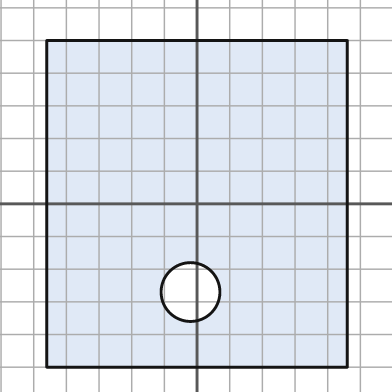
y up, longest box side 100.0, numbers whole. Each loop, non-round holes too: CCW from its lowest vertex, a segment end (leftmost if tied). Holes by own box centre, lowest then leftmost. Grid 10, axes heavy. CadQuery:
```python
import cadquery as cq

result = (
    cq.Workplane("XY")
    .moveTo(-46.0, -50.0)
    .lineTo(46.0, -50.0)
    .lineTo(46.0, 50.0)
    .lineTo(-46.0, 50.0)
    .close()
    .moveTo(-2.0, -27.0)
    .circle(9.0)
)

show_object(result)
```